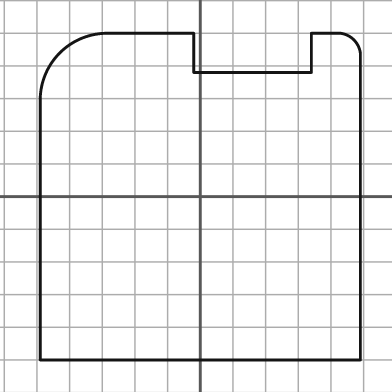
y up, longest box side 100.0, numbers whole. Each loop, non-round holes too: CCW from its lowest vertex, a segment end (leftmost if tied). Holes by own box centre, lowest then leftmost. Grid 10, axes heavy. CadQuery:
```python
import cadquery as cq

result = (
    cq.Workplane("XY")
    .moveTo(-49.0, -50.0)
    .lineTo(49.0, -50.0)
    .lineTo(49.0, 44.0)
    .threePointArc((47.0, 48.0), (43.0, 50.0))
    .lineTo(34.0, 50.0)
    .lineTo(34.0, 38.0)
    .lineTo(-2.0, 38.0)
    .lineTo(-2.0, 50.0)
    .lineTo(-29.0, 50.0)
    .threePointArc((-43.0, 44.0), (-49.0, 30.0))
    .close()
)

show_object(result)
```